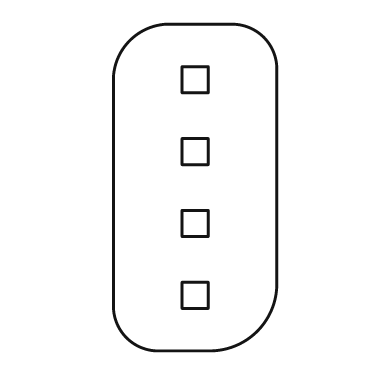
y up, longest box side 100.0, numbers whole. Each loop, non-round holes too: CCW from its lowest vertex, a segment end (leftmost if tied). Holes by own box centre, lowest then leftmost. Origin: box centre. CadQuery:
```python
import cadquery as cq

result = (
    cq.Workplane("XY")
    .moveTo(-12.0, -50.0)
    .lineTo(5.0, -50.0)
    .threePointArc((19.0, -44.0), (25.0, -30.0))
    .lineTo(25.0, 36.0)
    .threePointArc((21.0, 46.0), (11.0, 50.0))
    .lineTo(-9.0, 50.0)
    .threePointArc((-20.0, 45.0), (-25.0, 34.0))
    .lineTo(-25.0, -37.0)
    .threePointArc((-21.0, -46.0), (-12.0, -50.0))
    .close()
    .moveTo(-4.0, -37.0)
    .lineTo(4.0, -37.0)
    .lineTo(4.0, -29.0)
    .lineTo(-4.0, -29.0)
    .close()
    .moveTo(-4.0, -15.0)
    .lineTo(4.0, -15.0)
    .lineTo(4.0, -7.0)
    .lineTo(-4.0, -7.0)
    .close()
    .moveTo(-4.0, 7.0)
    .lineTo(4.0, 7.0)
    .lineTo(4.0, 15.0)
    .lineTo(-4.0, 15.0)
    .close()
    .moveTo(-4.0, 29.0)
    .lineTo(4.0, 29.0)
    .lineTo(4.0, 37.0)
    .lineTo(-4.0, 37.0)
    .close()
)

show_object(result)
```